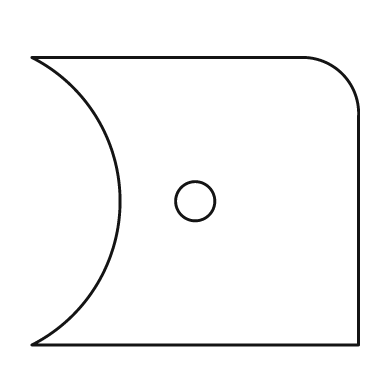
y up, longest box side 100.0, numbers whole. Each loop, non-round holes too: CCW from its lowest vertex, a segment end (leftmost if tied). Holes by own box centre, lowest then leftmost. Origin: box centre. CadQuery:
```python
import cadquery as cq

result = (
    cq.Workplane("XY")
    .moveTo(-50.0, -44.0)
    .lineTo(50.0, -44.0)
    .lineTo(50.0, 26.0)
    .threePointArc((45.0, 39.0), (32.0, 44.0))
    .lineTo(-50.0, 44.0)
    .threePointArc((-23.0, 0.0), (-50.0, -44.0))
    .close()
    .moveTo(0.0, 0.0)
    .circle(6.0)
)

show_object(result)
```